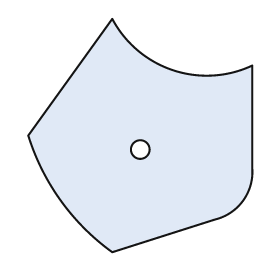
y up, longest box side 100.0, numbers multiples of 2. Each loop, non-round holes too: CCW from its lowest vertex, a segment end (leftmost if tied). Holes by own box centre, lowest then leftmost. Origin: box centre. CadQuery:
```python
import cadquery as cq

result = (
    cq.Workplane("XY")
    .moveTo(-12.0, -50.0)
    .lineTo(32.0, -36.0)
    .threePointArc((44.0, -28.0), (48.0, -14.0))
    .lineTo(48.0, 30.0)
    .threePointArc((14.0, 28.0), (-12.0, 50.0))
    .lineTo(-48.0, 0.0)
    .threePointArc((-34.0, -28.0), (-12.0, -50.0))
    .close()
    .moveTo(0.0, -6.0)
    .circle(4.0)
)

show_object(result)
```